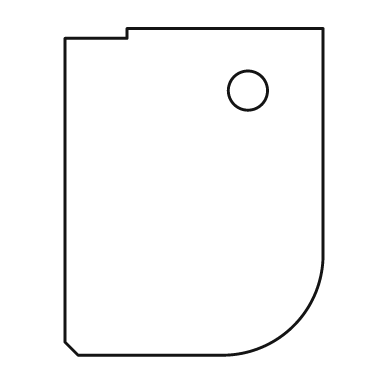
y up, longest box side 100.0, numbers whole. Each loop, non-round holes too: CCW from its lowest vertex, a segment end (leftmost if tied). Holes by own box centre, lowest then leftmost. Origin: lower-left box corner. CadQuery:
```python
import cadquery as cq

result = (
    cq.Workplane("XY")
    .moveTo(4.0, 0.0)
    .lineTo(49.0, 0.0)
    .threePointArc((70.0, 9.0), (79.0, 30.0))
    .lineTo(79.0, 100.0)
    .lineTo(19.0, 100.0)
    .lineTo(19.0, 97.0)
    .lineTo(0.0, 97.0)
    .lineTo(0.0, 4.0)
    .close()
    .moveTo(56.0, 81.0)
    .circle(6.0)
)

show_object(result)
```